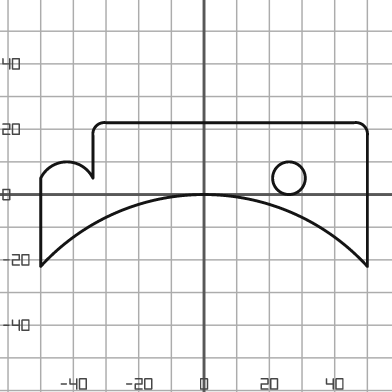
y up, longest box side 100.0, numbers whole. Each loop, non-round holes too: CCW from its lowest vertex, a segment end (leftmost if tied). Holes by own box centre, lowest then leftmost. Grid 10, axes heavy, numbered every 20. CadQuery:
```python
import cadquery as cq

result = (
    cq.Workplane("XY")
    .moveTo(-50.0, -22.0)
    .threePointArc((0.0, 0.0), (50.0, -22.0))
    .lineTo(50.0, 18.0)
    .threePointArc((49.0, 21.0), (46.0, 22.0))
    .lineTo(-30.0, 22.0)
    .threePointArc((-33.0, 21.0), (-34.0, 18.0))
    .lineTo(-34.0, 5.0)
    .threePointArc((-42.0, 10.0), (-50.0, 5.0))
    .close()
    .moveTo(26.0, 5.0)
    .circle(5.0)
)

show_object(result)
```